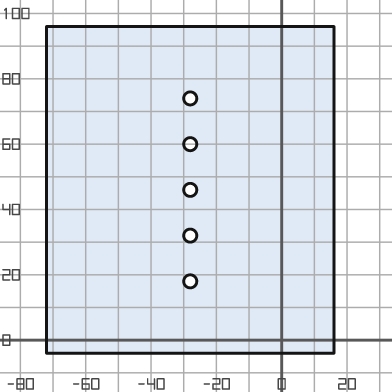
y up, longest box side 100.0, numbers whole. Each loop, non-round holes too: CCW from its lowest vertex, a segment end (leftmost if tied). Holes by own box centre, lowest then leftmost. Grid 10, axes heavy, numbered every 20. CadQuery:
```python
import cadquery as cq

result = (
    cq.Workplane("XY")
    .moveTo(-72.0, -4.0)
    .lineTo(16.0, -4.0)
    .lineTo(16.0, 96.0)
    .lineTo(-72.0, 96.0)
    .close()
    .moveTo(-28.0, 18.0)
    .circle(2.0)
    .moveTo(-28.0, 32.0)
    .circle(2.0)
    .moveTo(-28.0, 46.0)
    .circle(2.0)
    .moveTo(-28.0, 60.0)
    .circle(2.0)
    .moveTo(-28.0, 74.0)
    .circle(2.0)
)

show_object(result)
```